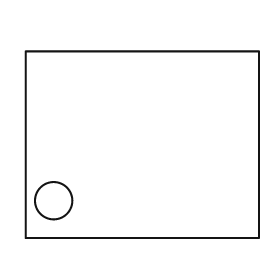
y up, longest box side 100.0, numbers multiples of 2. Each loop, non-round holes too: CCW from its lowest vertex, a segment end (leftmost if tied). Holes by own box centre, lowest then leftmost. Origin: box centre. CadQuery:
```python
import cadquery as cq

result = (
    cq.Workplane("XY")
    .moveTo(-50.0, -40.0)
    .lineTo(50.0, -40.0)
    .lineTo(50.0, 40.0)
    .lineTo(-50.0, 40.0)
    .close()
    .moveTo(-38.0, -24.0)
    .circle(8.0)
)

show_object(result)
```